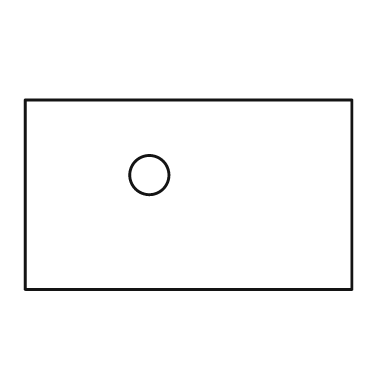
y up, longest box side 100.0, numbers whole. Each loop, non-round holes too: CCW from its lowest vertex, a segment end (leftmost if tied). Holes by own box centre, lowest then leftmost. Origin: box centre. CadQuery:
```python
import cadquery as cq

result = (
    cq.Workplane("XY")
    .moveTo(-50.0, -29.0)
    .lineTo(50.0, -29.0)
    .lineTo(50.0, 29.0)
    .lineTo(-50.0, 29.0)
    .close()
    .moveTo(-12.0, 6.0)
    .circle(6.0)
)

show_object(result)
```